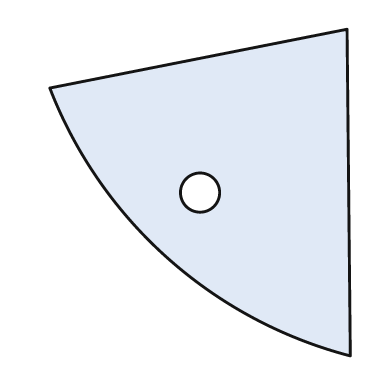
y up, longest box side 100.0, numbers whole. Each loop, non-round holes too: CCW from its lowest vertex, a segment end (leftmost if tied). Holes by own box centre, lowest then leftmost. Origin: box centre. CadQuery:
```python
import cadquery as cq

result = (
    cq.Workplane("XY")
    .moveTo(46.0, -50.0)
    .lineTo(45.0, 50.0)
    .lineTo(-46.0, 32.0)
    .threePointArc((-10.0, -20.0), (46.0, -50.0))
    .close()
    .moveTo(0.0, 0.0)
    .circle(6.0)
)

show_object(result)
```